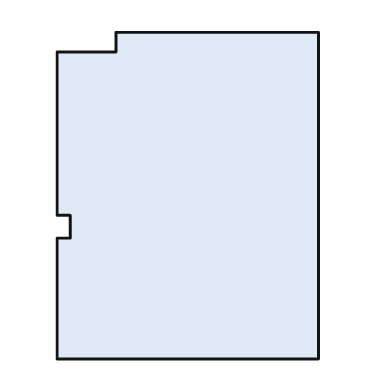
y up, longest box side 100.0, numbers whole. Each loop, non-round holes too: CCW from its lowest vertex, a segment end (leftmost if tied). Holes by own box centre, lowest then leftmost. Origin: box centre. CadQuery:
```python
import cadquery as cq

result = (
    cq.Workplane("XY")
    .moveTo(-40.0, -50.0)
    .lineTo(40.0, -50.0)
    .lineTo(40.0, 50.0)
    .lineTo(-22.0, 50.0)
    .lineTo(-22.0, 44.0)
    .lineTo(-40.0, 44.0)
    .lineTo(-40.0, -6.0)
    .lineTo(-36.0, -6.0)
    .lineTo(-36.0, -13.0)
    .lineTo(-40.0, -13.0)
    .close()
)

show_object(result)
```